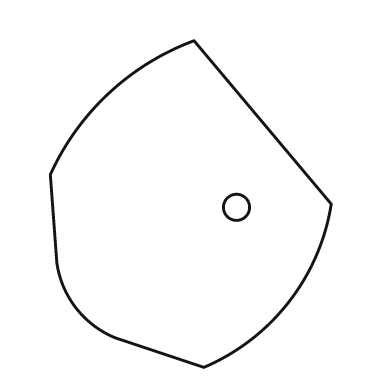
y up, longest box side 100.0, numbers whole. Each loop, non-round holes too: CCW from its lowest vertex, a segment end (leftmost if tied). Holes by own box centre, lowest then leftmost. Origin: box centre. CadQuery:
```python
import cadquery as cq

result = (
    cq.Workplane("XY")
    .moveTo(4.0, -50.0)
    .threePointArc((30.0, -30.0), (43.0, 0.0))
    .lineTo(1.0, 50.0)
    .threePointArc((-25.0, 34.0), (-43.0, 9.0))
    .lineTo(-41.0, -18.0)
    .threePointArc((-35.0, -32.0), (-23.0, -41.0))
    .close()
    .moveTo(14.0, -1.0)
    .circle(4.0)
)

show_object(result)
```